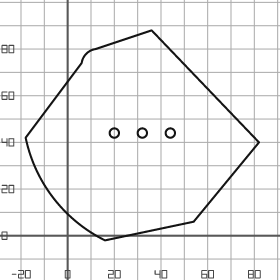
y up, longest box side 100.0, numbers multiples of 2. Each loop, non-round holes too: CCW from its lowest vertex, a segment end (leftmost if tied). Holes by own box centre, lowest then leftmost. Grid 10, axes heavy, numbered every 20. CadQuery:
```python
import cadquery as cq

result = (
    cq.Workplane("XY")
    .moveTo(16.0, -2.0)
    .lineTo(54.0, 6.0)
    .lineTo(82.0, 40.0)
    .lineTo(36.0, 88.0)
    .lineTo(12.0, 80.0)
    .threePointArc((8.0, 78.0), (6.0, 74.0))
    .lineTo(-18.0, 42.0)
    .threePointArc((-6.0, 16.0), (16.0, -2.0))
    .close()
    .moveTo(20.0, 44.0)
    .circle(2.0)
    .moveTo(32.0, 44.0)
    .circle(2.0)
    .moveTo(44.0, 44.0)
    .circle(2.0)
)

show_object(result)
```